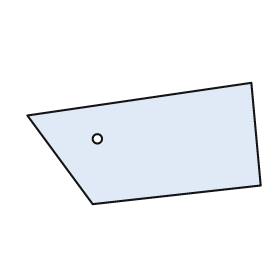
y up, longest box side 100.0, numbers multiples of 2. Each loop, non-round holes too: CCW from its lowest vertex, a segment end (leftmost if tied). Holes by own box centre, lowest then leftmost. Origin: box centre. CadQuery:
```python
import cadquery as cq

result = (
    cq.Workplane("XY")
    .moveTo(-22.0, -26.0)
    .lineTo(50.0, -18.0)
    .lineTo(46.0, 26.0)
    .lineTo(-50.0, 12.0)
    .close()
    .moveTo(-20.0, 2.0)
    .circle(2.0)
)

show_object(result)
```